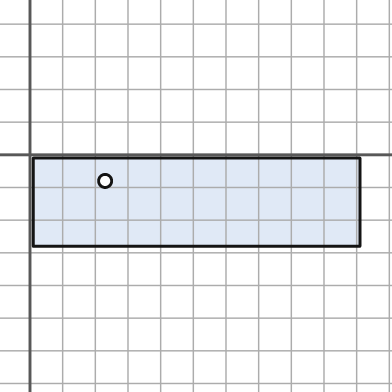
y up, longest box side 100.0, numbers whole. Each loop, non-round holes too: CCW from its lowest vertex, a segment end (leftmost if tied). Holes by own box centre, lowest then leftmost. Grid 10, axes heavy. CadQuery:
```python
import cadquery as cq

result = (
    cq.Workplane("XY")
    .moveTo(1.0, -28.0)
    .lineTo(101.0, -28.0)
    .lineTo(101.0, -1.0)
    .lineTo(1.0, -1.0)
    .close()
    .moveTo(23.0, -8.0)
    .circle(2.0)
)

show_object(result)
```